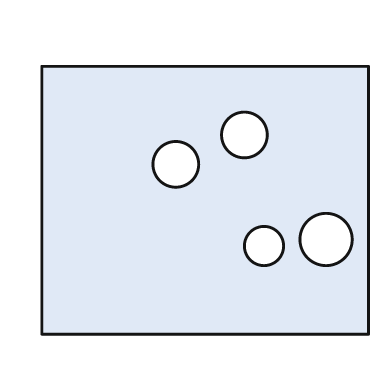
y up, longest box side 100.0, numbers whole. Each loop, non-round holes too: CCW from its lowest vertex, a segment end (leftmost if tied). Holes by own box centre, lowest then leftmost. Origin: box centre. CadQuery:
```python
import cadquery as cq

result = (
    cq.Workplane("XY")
    .moveTo(-50.0, -41.0)
    .lineTo(50.0, -41.0)
    .lineTo(50.0, 41.0)
    .lineTo(-50.0, 41.0)
    .close()
    .moveTo(18.0, -14.0)
    .circle(6.0)
    .moveTo(37.0, -12.0)
    .circle(8.0)
    .moveTo(-9.0, 11.0)
    .circle(7.0)
    .moveTo(12.0, 20.0)
    .circle(7.0)
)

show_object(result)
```